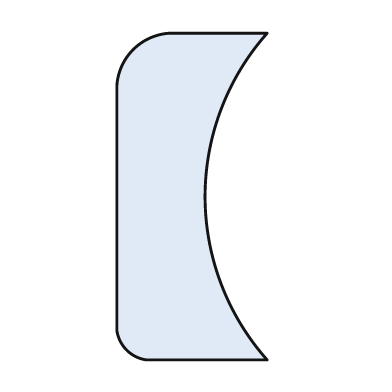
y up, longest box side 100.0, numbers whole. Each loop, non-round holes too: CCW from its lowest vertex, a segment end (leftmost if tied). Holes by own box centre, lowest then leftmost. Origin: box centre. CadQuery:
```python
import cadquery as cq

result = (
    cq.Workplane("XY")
    .moveTo(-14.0, -50.0)
    .lineTo(23.0, -50.0)
    .threePointArc((4.0, 0.0), (23.0, 50.0))
    .lineTo(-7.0, 50.0)
    .threePointArc((-18.0, 45.0), (-23.0, 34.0))
    .lineTo(-23.0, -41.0)
    .threePointArc((-20.0, -47.0), (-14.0, -50.0))
    .close()
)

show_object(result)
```